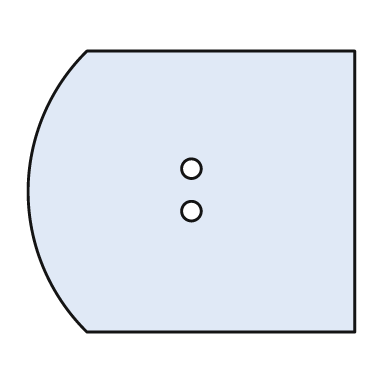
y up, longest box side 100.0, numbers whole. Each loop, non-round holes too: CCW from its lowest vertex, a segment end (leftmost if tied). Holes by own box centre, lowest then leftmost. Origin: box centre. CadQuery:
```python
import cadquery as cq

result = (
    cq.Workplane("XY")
    .moveTo(-32.0, -43.0)
    .lineTo(50.0, -43.0)
    .lineTo(50.0, 43.0)
    .lineTo(-32.0, 43.0)
    .threePointArc((-50.0, 0.0), (-32.0, -43.0))
    .close()
    .moveTo(0.0, -6.0)
    .circle(3.0)
    .moveTo(0.0, 7.0)
    .circle(3.0)
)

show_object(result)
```